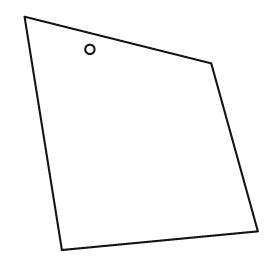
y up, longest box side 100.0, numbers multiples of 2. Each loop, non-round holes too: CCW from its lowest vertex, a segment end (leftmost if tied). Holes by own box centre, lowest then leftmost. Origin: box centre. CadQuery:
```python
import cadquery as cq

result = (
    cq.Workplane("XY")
    .moveTo(-34.0, -50.0)
    .lineTo(50.0, -42.0)
    .lineTo(30.0, 30.0)
    .lineTo(-50.0, 50.0)
    .close()
    .moveTo(-22.0, 36.0)
    .circle(2.0)
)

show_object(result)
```